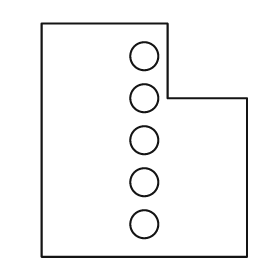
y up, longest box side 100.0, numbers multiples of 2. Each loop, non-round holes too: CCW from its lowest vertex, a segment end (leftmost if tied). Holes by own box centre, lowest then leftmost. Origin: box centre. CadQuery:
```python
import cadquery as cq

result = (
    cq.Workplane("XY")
    .moveTo(-44.0, -50.0)
    .lineTo(44.0, -50.0)
    .lineTo(44.0, 18.0)
    .lineTo(10.0, 18.0)
    .lineTo(10.0, 50.0)
    .lineTo(-44.0, 50.0)
    .close()
    .moveTo(0.0, -36.0)
    .circle(6.0)
    .moveTo(0.0, -18.0)
    .circle(6.0)
    .moveTo(0.0, 0.0)
    .circle(6.0)
    .moveTo(0.0, 18.0)
    .circle(6.0)
    .moveTo(0.0, 36.0)
    .circle(6.0)
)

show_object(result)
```